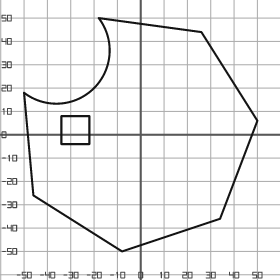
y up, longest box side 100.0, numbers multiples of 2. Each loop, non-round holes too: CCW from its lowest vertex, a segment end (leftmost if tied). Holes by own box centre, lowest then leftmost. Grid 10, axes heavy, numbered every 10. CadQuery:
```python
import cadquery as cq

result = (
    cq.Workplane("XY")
    .moveTo(-8.0, -50.0)
    .lineTo(34.0, -36.0)
    .lineTo(50.0, 6.0)
    .lineTo(26.0, 44.0)
    .lineTo(-18.0, 50.0)
    .threePointArc((-20.0, 20.0), (-50.0, 18.0))
    .lineTo(-46.0, -26.0)
    .close()
    .moveTo(-34.0, -4.0)
    .lineTo(-22.0, -4.0)
    .lineTo(-22.0, 8.0)
    .lineTo(-34.0, 8.0)
    .close()
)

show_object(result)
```